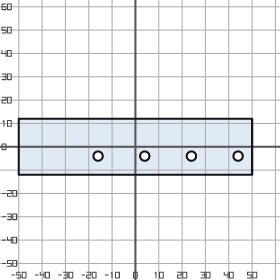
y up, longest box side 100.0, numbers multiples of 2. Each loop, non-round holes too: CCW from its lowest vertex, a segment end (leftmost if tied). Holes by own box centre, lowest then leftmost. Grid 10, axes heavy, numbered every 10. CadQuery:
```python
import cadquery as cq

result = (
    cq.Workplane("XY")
    .moveTo(-50.0, -12.0)
    .lineTo(50.0, -12.0)
    .lineTo(50.0, 12.0)
    .lineTo(-50.0, 12.0)
    .close()
    .moveTo(-16.0, -4.0)
    .circle(2.0)
    .moveTo(4.0, -4.0)
    .circle(2.0)
    .moveTo(24.0, -4.0)
    .circle(2.0)
    .moveTo(44.0, -4.0)
    .circle(2.0)
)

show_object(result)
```